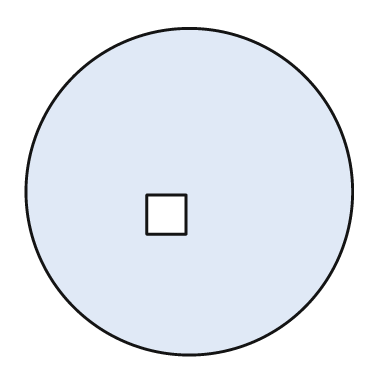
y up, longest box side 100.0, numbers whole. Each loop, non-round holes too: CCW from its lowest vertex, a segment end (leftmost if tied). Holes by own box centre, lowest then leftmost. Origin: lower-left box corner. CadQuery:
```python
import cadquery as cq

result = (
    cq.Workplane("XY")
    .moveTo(50.0, 50.0)
    .circle(50.0)
    .moveTo(37.0, 37.0)
    .lineTo(49.0, 37.0)
    .lineTo(49.0, 49.0)
    .lineTo(37.0, 49.0)
    .close()
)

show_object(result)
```